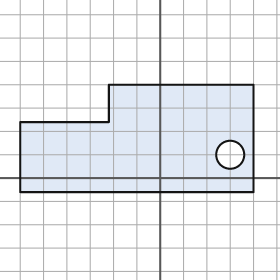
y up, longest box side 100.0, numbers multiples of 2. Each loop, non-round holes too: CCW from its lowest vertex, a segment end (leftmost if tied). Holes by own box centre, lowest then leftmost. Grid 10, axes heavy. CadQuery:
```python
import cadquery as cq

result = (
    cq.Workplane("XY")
    .moveTo(-60.0, -6.0)
    .lineTo(40.0, -6.0)
    .lineTo(40.0, 40.0)
    .lineTo(-22.0, 40.0)
    .lineTo(-22.0, 24.0)
    .lineTo(-60.0, 24.0)
    .close()
    .moveTo(30.0, 10.0)
    .circle(6.0)
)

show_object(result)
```